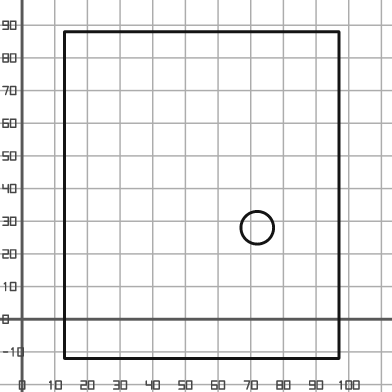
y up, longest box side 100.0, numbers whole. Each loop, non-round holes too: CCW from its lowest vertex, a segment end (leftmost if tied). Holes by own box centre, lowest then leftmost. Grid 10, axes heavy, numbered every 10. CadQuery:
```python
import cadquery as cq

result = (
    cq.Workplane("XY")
    .moveTo(13.0, -12.0)
    .lineTo(97.0, -12.0)
    .lineTo(97.0, 88.0)
    .lineTo(13.0, 88.0)
    .close()
    .moveTo(72.0, 28.0)
    .circle(5.0)
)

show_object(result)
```